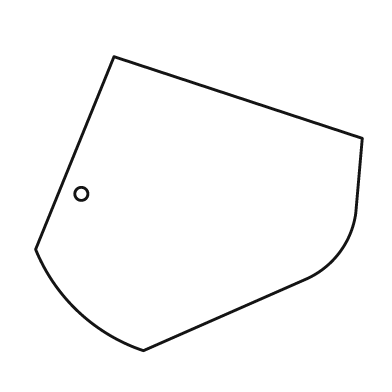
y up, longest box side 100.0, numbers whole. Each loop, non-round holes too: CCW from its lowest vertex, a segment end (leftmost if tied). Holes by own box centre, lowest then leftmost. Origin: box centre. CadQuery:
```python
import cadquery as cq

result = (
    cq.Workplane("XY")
    .moveTo(-17.0, -45.0)
    .lineTo(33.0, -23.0)
    .threePointArc((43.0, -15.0), (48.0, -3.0))
    .lineTo(50.0, 20.0)
    .lineTo(-26.0, 45.0)
    .lineTo(-50.0, -14.0)
    .threePointArc((-37.0, -33.0), (-17.0, -45.0))
    .close()
    .moveTo(-36.0, 3.0)
    .circle(2.0)
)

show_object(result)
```